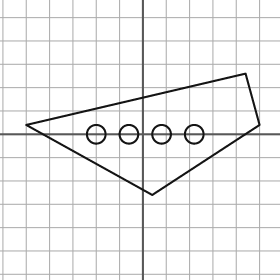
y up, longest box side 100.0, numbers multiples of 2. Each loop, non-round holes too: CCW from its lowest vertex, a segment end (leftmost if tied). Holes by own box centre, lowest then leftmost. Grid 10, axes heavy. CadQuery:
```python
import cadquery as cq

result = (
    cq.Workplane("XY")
    .moveTo(4.0, -26.0)
    .lineTo(50.0, 4.0)
    .lineTo(44.0, 26.0)
    .lineTo(-50.0, 4.0)
    .close()
    .moveTo(-20.0, 0.0)
    .circle(4.0)
    .moveTo(-6.0, 0.0)
    .circle(4.0)
    .moveTo(8.0, 0.0)
    .circle(4.0)
    .moveTo(22.0, 0.0)
    .circle(4.0)
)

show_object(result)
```